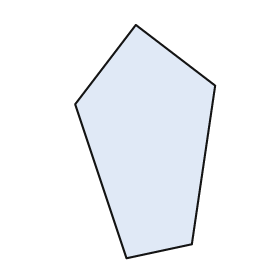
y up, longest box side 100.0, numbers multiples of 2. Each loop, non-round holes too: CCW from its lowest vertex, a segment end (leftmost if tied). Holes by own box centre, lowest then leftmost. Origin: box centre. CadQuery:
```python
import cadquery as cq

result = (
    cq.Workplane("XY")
    .moveTo(-8.0, -50.0)
    .lineTo(20.0, -44.0)
    .lineTo(30.0, 24.0)
    .lineTo(-4.0, 50.0)
    .lineTo(-30.0, 16.0)
    .close()
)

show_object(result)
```